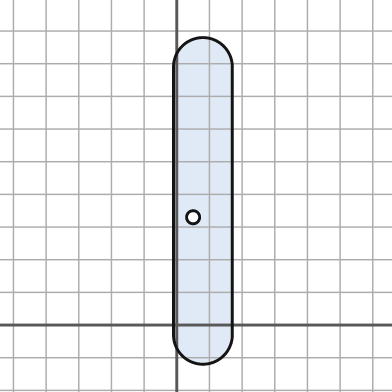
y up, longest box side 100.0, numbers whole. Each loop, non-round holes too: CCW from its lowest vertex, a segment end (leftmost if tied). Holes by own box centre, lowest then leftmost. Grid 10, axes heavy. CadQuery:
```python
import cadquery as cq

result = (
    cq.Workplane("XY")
    .moveTo(-1.0, -3.0)
    .threePointArc((8.0, -12.0), (17.0, -3.0))
    .lineTo(17.0, 79.0)
    .threePointArc((8.0, 88.0), (-1.0, 79.0))
    .close()
    .moveTo(5.0, 33.0)
    .circle(2.0)
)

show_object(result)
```